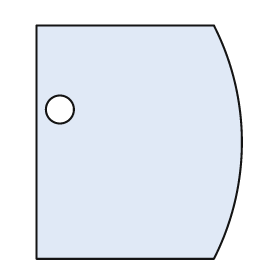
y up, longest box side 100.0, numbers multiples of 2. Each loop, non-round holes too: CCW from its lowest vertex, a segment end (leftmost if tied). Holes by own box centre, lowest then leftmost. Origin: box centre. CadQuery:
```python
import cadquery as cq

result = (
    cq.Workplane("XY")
    .moveTo(-44.0, -50.0)
    .lineTo(32.0, -50.0)
    .threePointArc((44.0, 0.0), (32.0, 50.0))
    .lineTo(-44.0, 50.0)
    .close()
    .moveTo(-34.0, 14.0)
    .circle(6.0)
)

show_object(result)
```